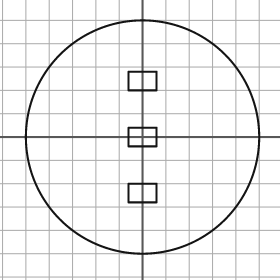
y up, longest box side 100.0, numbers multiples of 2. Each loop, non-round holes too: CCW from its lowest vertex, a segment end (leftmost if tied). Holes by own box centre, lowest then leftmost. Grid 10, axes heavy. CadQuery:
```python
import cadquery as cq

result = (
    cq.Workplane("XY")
    .moveTo(0.0, 0.0)
    .circle(50.0)
    .moveTo(-6.0, -28.0)
    .lineTo(6.0, -28.0)
    .lineTo(6.0, -20.0)
    .lineTo(-6.0, -20.0)
    .close()
    .moveTo(-6.0, -4.0)
    .lineTo(6.0, -4.0)
    .lineTo(6.0, 4.0)
    .lineTo(-6.0, 4.0)
    .close()
    .moveTo(-6.0, 20.0)
    .lineTo(6.0, 20.0)
    .lineTo(6.0, 28.0)
    .lineTo(-6.0, 28.0)
    .close()
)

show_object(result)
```